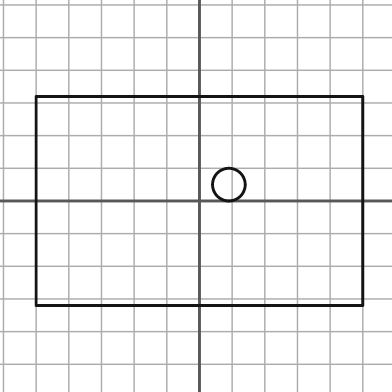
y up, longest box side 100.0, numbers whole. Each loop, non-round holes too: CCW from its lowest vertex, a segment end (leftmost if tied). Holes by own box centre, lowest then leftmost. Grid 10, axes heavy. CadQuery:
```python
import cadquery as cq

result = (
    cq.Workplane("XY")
    .moveTo(-50.0, -32.0)
    .lineTo(50.0, -32.0)
    .lineTo(50.0, 32.0)
    .lineTo(-50.0, 32.0)
    .close()
    .moveTo(9.0, 5.0)
    .circle(5.0)
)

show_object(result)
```